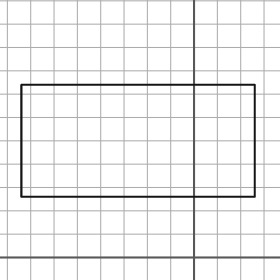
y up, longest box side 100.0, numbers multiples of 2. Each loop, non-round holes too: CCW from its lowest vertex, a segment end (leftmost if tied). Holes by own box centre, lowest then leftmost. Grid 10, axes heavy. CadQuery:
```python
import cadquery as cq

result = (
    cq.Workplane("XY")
    .moveTo(-74.0, 26.0)
    .lineTo(26.0, 26.0)
    .lineTo(26.0, 74.0)
    .lineTo(-74.0, 74.0)
    .close()
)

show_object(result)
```